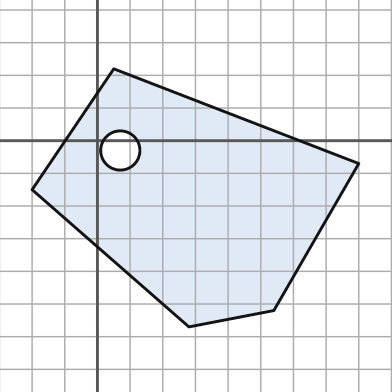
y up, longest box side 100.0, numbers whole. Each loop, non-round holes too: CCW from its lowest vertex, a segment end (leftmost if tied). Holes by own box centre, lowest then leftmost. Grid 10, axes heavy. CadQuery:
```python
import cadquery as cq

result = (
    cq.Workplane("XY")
    .moveTo(28.0, -57.0)
    .lineTo(54.0, -52.0)
    .lineTo(80.0, -7.0)
    .lineTo(5.0, 22.0)
    .lineTo(-20.0, -15.0)
    .close()
    .moveTo(7.0, -3.0)
    .circle(6.0)
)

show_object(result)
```